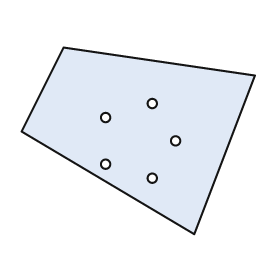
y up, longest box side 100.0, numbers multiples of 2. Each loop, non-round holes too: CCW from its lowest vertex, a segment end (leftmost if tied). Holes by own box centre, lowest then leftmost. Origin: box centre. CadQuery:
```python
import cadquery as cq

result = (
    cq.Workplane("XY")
    .moveTo(24.0, -40.0)
    .lineTo(50.0, 28.0)
    .lineTo(-32.0, 40.0)
    .lineTo(-50.0, 4.0)
    .close()
    .moveTo(6.0, -16.0)
    .circle(2.0)
    .moveTo(-14.0, -10.0)
    .circle(2.0)
    .moveTo(16.0, 0.0)
    .circle(2.0)
    .moveTo(-14.0, 10.0)
    .circle(2.0)
    .moveTo(6.0, 16.0)
    .circle(2.0)
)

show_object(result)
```